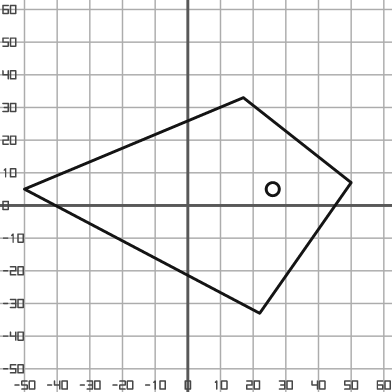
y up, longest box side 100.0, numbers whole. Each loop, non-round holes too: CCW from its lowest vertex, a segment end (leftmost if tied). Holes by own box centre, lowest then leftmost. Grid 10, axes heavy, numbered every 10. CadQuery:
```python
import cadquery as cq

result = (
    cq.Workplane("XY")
    .moveTo(22.0, -33.0)
    .lineTo(50.0, 7.0)
    .lineTo(17.0, 33.0)
    .lineTo(-50.0, 5.0)
    .close()
    .moveTo(26.0, 5.0)
    .circle(2.0)
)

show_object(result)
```